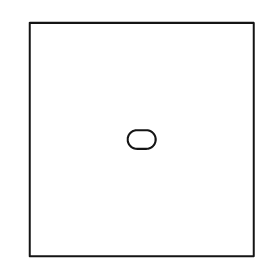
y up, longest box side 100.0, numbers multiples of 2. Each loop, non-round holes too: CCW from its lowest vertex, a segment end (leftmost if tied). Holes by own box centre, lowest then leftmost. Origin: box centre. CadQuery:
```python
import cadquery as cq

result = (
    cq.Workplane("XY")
    .moveTo(-48.0, -50.0)
    .lineTo(48.0, -50.0)
    .lineTo(48.0, 50.0)
    .lineTo(-48.0, 50.0)
    .close()
    .moveTo(-2.0, -4.0)
    .lineTo(2.0, -4.0)
    .threePointArc((6.0, 0.0), (2.0, 4.0))
    .lineTo(-2.0, 4.0)
    .threePointArc((-6.0, 0.0), (-2.0, -4.0))
    .close()
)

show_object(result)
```